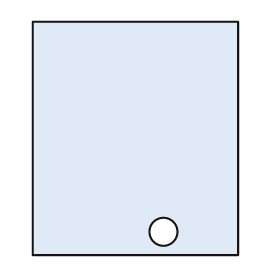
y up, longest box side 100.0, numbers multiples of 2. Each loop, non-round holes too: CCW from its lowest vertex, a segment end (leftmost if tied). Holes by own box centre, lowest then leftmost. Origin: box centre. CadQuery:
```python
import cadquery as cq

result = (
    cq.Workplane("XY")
    .moveTo(-44.0, -50.0)
    .lineTo(44.0, -50.0)
    .lineTo(44.0, 50.0)
    .lineTo(-44.0, 50.0)
    .close()
    .moveTo(12.0, -40.0)
    .circle(6.0)
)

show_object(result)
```